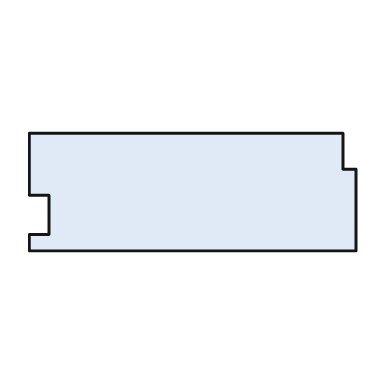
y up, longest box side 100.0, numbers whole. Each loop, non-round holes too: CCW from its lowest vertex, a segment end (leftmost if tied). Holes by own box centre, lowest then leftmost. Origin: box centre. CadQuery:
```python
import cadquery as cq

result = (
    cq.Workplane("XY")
    .moveTo(-50.0, -18.0)
    .lineTo(50.0, -18.0)
    .lineTo(50.0, 7.0)
    .lineTo(46.0, 7.0)
    .lineTo(46.0, 18.0)
    .lineTo(-50.0, 18.0)
    .lineTo(-50.0, -1.0)
    .lineTo(-44.0, -1.0)
    .lineTo(-44.0, -13.0)
    .lineTo(-50.0, -13.0)
    .close()
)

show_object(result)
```